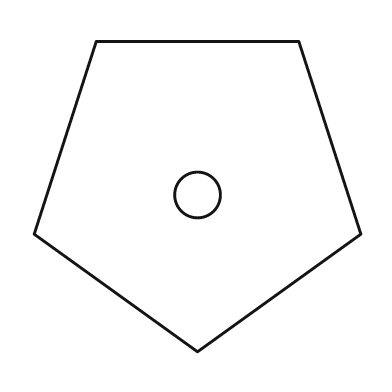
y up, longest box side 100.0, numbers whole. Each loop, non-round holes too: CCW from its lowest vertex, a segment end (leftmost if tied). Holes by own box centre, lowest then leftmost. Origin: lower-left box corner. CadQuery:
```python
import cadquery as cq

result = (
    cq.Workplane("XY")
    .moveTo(50.0, 0.0)
    .lineTo(100.0, 36.0)
    .lineTo(81.0, 95.0)
    .lineTo(19.0, 95.0)
    .lineTo(0.0, 36.0)
    .close()
    .moveTo(50.0, 48.0)
    .circle(7.0)
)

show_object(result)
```